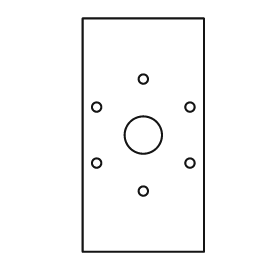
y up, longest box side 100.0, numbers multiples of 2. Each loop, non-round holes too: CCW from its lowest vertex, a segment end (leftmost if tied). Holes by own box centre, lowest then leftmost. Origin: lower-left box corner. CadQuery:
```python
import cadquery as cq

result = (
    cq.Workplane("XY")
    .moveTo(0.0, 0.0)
    .lineTo(52.0, 0.0)
    .lineTo(52.0, 100.0)
    .lineTo(0.0, 100.0)
    .close()
    .moveTo(26.0, 26.0)
    .circle(2.0)
    .moveTo(6.0, 38.0)
    .circle(2.0)
    .moveTo(46.0, 38.0)
    .circle(2.0)
    .moveTo(26.0, 50.0)
    .circle(8.0)
    .moveTo(6.0, 62.0)
    .circle(2.0)
    .moveTo(46.0, 62.0)
    .circle(2.0)
    .moveTo(26.0, 74.0)
    .circle(2.0)
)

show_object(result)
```